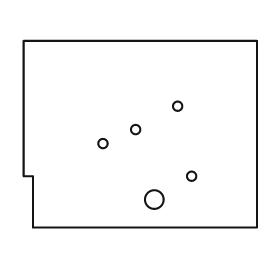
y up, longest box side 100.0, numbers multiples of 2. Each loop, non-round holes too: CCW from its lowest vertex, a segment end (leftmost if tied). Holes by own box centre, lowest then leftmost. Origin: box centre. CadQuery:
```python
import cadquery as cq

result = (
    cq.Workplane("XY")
    .moveTo(-46.0, -40.0)
    .lineTo(50.0, -40.0)
    .lineTo(50.0, 40.0)
    .lineTo(-50.0, 40.0)
    .lineTo(-50.0, -18.0)
    .lineTo(-46.0, -18.0)
    .close()
    .moveTo(6.0, -28.0)
    .circle(4.0)
    .moveTo(22.0, -18.0)
    .circle(2.0)
    .moveTo(-16.0, -4.0)
    .circle(2.0)
    .moveTo(-2.0, 2.0)
    .circle(2.0)
    .moveTo(16.0, 12.0)
    .circle(2.0)
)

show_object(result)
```